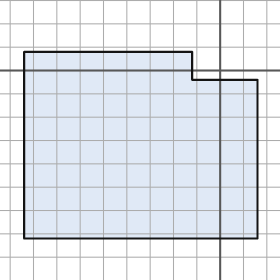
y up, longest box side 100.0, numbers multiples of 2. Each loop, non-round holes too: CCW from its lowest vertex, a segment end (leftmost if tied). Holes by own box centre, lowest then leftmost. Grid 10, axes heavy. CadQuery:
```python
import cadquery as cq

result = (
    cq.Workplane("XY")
    .moveTo(-84.0, -72.0)
    .lineTo(16.0, -72.0)
    .lineTo(16.0, -4.0)
    .lineTo(-12.0, -4.0)
    .lineTo(-12.0, 8.0)
    .lineTo(-84.0, 8.0)
    .close()
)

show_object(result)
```